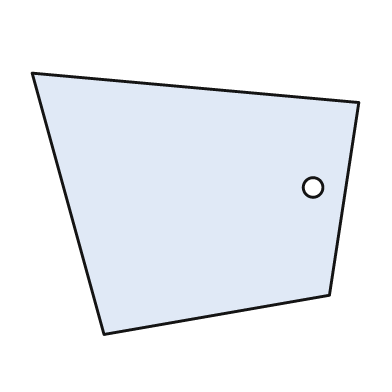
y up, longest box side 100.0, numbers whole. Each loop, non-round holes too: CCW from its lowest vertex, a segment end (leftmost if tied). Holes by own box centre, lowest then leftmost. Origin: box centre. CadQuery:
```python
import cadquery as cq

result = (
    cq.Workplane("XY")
    .moveTo(-28.0, -40.0)
    .lineTo(41.0, -28.0)
    .lineTo(50.0, 31.0)
    .lineTo(-50.0, 40.0)
    .close()
    .moveTo(36.0, 5.0)
    .circle(3.0)
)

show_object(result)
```